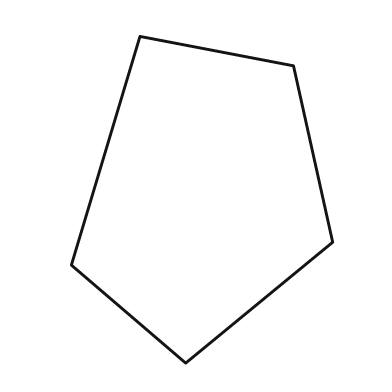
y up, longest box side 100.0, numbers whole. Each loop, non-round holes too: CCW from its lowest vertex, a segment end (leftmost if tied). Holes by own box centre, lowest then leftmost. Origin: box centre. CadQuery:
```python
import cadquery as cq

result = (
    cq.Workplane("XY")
    .moveTo(-5.0, -50.0)
    .lineTo(40.0, -13.0)
    .lineTo(28.0, 41.0)
    .lineTo(-19.0, 50.0)
    .lineTo(-40.0, -20.0)
    .close()
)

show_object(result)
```